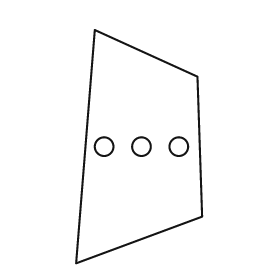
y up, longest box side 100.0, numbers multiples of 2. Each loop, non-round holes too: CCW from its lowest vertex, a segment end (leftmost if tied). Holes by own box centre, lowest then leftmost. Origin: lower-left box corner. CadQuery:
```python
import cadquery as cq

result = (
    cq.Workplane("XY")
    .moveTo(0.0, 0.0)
    .lineTo(54.0, 20.0)
    .lineTo(52.0, 80.0)
    .lineTo(8.0, 100.0)
    .close()
    .moveTo(12.0, 50.0)
    .circle(4.0)
    .moveTo(28.0, 50.0)
    .circle(4.0)
    .moveTo(44.0, 50.0)
    .circle(4.0)
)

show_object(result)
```